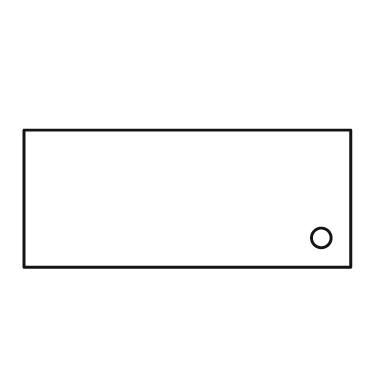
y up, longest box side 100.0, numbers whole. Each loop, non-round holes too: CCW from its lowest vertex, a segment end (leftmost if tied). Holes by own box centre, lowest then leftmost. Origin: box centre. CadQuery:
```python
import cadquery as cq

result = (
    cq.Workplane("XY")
    .moveTo(-50.0, -21.0)
    .lineTo(50.0, -21.0)
    .lineTo(50.0, 21.0)
    .lineTo(-50.0, 21.0)
    .close()
    .moveTo(41.0, -12.0)
    .circle(3.0)
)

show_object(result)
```